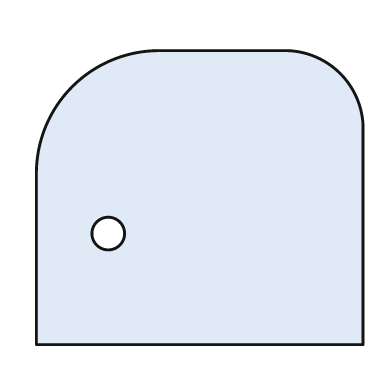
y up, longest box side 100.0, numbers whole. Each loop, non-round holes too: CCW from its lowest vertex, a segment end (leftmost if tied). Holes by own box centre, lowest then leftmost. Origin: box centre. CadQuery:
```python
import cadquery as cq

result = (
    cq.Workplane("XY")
    .moveTo(-50.0, -45.0)
    .lineTo(50.0, -45.0)
    .lineTo(50.0, 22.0)
    .threePointArc((43.0, 38.0), (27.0, 45.0))
    .lineTo(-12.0, 45.0)
    .threePointArc((-39.0, 34.0), (-50.0, 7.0))
    .close()
    .moveTo(-28.0, -11.0)
    .circle(5.0)
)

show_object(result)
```